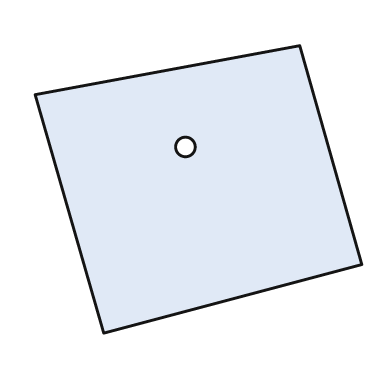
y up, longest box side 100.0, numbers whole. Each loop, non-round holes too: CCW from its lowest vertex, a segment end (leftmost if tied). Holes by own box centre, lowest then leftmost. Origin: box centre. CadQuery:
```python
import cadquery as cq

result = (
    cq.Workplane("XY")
    .moveTo(-29.0, -44.0)
    .lineTo(50.0, -23.0)
    .lineTo(31.0, 44.0)
    .lineTo(-50.0, 29.0)
    .close()
    .moveTo(-4.0, 13.0)
    .circle(3.0)
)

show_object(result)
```